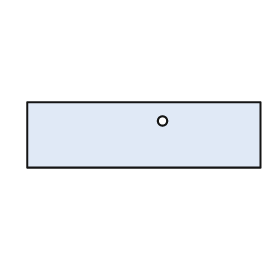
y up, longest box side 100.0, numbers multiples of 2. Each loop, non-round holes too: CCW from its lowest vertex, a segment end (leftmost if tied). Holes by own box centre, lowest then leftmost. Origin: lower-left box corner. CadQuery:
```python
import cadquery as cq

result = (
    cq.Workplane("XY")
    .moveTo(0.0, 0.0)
    .lineTo(100.0, 0.0)
    .lineTo(100.0, 28.0)
    .lineTo(0.0, 28.0)
    .close()
    .moveTo(58.0, 20.0)
    .circle(2.0)
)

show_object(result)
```